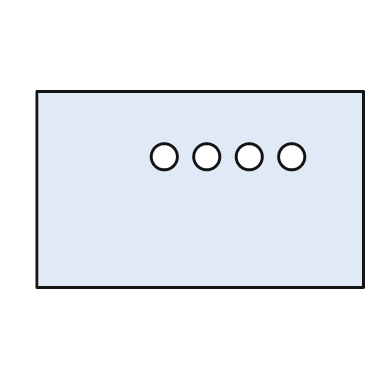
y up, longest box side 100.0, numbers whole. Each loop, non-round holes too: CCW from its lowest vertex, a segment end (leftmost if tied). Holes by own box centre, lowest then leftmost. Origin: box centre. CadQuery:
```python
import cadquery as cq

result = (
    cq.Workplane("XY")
    .moveTo(-50.0, -30.0)
    .lineTo(50.0, -30.0)
    .lineTo(50.0, 30.0)
    .lineTo(-50.0, 30.0)
    .close()
    .moveTo(-11.0, 10.0)
    .circle(4.0)
    .moveTo(2.0, 10.0)
    .circle(4.0)
    .moveTo(15.0, 10.0)
    .circle(4.0)
    .moveTo(28.0, 10.0)
    .circle(4.0)
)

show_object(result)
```